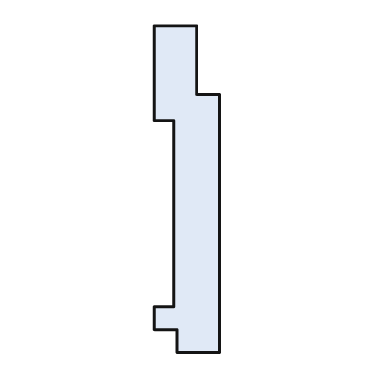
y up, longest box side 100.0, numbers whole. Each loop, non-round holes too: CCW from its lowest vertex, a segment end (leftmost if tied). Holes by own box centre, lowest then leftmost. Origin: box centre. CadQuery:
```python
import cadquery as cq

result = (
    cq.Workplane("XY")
    .moveTo(-3.0, -50.0)
    .lineTo(10.0, -50.0)
    .lineTo(10.0, 29.0)
    .lineTo(3.0, 29.0)
    .lineTo(3.0, 50.0)
    .lineTo(-10.0, 50.0)
    .lineTo(-10.0, 21.0)
    .lineTo(-4.0, 21.0)
    .lineTo(-4.0, -36.0)
    .lineTo(-10.0, -36.0)
    .lineTo(-10.0, -43.0)
    .lineTo(-3.0, -43.0)
    .close()
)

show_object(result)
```